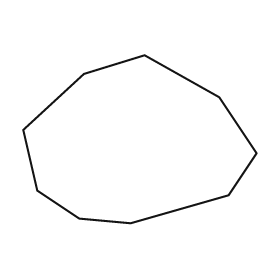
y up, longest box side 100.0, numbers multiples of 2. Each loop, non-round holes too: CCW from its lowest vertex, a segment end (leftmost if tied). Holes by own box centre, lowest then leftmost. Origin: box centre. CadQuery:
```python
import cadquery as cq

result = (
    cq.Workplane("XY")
    .moveTo(-4.0, -36.0)
    .lineTo(38.0, -24.0)
    .lineTo(50.0, -6.0)
    .lineTo(34.0, 18.0)
    .lineTo(2.0, 36.0)
    .lineTo(-24.0, 28.0)
    .lineTo(-50.0, 4.0)
    .lineTo(-44.0, -22.0)
    .lineTo(-26.0, -34.0)
    .close()
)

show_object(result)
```